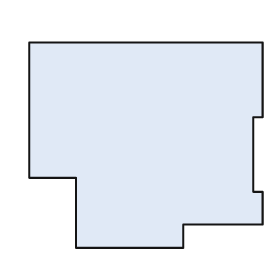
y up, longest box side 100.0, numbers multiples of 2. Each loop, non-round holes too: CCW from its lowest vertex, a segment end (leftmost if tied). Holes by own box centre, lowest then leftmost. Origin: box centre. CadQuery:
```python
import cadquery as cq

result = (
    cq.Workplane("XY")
    .moveTo(-30.0, -44.0)
    .lineTo(16.0, -44.0)
    .lineTo(16.0, -34.0)
    .lineTo(50.0, -34.0)
    .lineTo(50.0, -20.0)
    .lineTo(46.0, -20.0)
    .lineTo(46.0, 12.0)
    .lineTo(50.0, 12.0)
    .lineTo(50.0, 44.0)
    .lineTo(-50.0, 44.0)
    .lineTo(-50.0, -14.0)
    .lineTo(-30.0, -14.0)
    .close()
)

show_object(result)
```